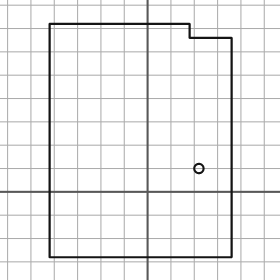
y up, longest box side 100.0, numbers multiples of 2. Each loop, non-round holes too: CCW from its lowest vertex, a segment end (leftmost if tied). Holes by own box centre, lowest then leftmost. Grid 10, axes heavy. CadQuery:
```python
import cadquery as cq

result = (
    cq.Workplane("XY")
    .moveTo(-42.0, -28.0)
    .lineTo(36.0, -28.0)
    .lineTo(36.0, 66.0)
    .lineTo(18.0, 66.0)
    .lineTo(18.0, 72.0)
    .lineTo(-42.0, 72.0)
    .close()
    .moveTo(22.0, 10.0)
    .circle(2.0)
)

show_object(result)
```